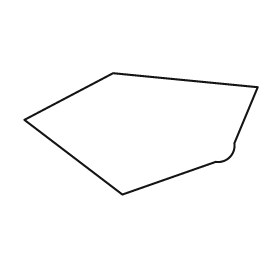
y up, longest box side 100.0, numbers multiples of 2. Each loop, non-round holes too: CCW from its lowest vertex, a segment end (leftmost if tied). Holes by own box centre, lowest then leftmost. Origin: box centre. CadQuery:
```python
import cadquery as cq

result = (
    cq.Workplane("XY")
    .moveTo(-8.0, -26.0)
    .lineTo(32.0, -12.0)
    .threePointArc((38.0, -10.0), (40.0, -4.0))
    .lineTo(50.0, 20.0)
    .lineTo(-12.0, 26.0)
    .lineTo(-50.0, 6.0)
    .close()
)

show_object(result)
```